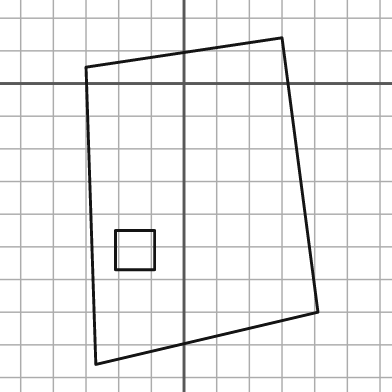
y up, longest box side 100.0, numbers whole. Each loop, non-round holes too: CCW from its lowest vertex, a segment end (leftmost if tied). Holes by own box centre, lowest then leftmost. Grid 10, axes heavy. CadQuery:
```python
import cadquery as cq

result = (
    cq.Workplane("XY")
    .moveTo(-27.0, -86.0)
    .lineTo(41.0, -70.0)
    .lineTo(30.0, 14.0)
    .lineTo(-30.0, 5.0)
    .close()
    .moveTo(-21.0, -57.0)
    .lineTo(-9.0, -57.0)
    .lineTo(-9.0, -45.0)
    .lineTo(-21.0, -45.0)
    .close()
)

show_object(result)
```